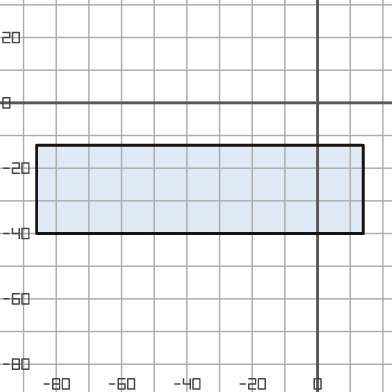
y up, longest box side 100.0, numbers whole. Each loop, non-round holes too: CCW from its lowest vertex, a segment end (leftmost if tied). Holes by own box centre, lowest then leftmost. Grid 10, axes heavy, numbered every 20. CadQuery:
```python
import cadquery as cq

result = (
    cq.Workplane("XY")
    .moveTo(-86.0, -40.0)
    .lineTo(14.0, -40.0)
    .lineTo(14.0, -13.0)
    .lineTo(-86.0, -13.0)
    .close()
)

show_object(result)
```